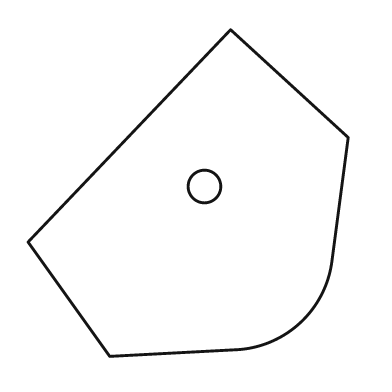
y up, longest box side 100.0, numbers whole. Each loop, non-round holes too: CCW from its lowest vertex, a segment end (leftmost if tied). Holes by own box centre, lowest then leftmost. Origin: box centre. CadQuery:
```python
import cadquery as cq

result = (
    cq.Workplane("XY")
    .moveTo(-24.0, -50.0)
    .lineTo(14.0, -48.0)
    .threePointArc((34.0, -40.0), (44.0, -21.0))
    .lineTo(49.0, 17.0)
    .lineTo(13.0, 50.0)
    .lineTo(-49.0, -15.0)
    .close()
    .moveTo(5.0, 2.0)
    .circle(5.0)
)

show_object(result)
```